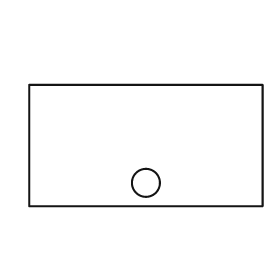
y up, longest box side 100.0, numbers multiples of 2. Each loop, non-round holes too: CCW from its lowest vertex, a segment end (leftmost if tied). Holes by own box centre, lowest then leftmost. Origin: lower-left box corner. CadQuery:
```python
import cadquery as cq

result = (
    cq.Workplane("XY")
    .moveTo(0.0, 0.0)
    .lineTo(100.0, 0.0)
    .lineTo(100.0, 52.0)
    .lineTo(0.0, 52.0)
    .close()
    .moveTo(50.0, 10.0)
    .circle(6.0)
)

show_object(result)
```